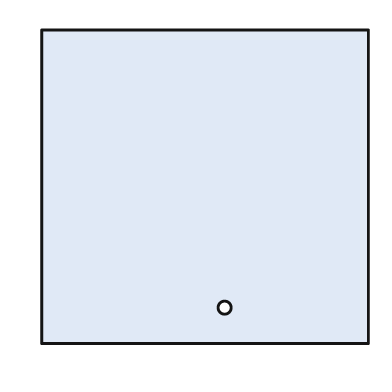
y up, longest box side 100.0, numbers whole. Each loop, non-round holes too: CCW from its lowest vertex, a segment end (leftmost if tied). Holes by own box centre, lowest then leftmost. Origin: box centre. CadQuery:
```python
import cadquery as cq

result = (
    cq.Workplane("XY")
    .moveTo(-50.0, -48.0)
    .lineTo(50.0, -48.0)
    .lineTo(50.0, 48.0)
    .lineTo(-50.0, 48.0)
    .close()
    .moveTo(6.0, -37.0)
    .circle(2.0)
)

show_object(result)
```